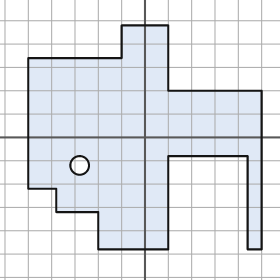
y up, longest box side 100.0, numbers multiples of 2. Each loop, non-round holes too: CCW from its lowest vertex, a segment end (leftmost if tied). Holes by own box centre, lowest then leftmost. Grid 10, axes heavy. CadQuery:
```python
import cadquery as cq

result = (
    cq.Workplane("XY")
    .moveTo(-20.0, -48.0)
    .lineTo(10.0, -48.0)
    .lineTo(10.0, -8.0)
    .lineTo(44.0, -8.0)
    .lineTo(44.0, -48.0)
    .lineTo(50.0, -48.0)
    .lineTo(50.0, 20.0)
    .lineTo(10.0, 20.0)
    .lineTo(10.0, 48.0)
    .lineTo(-10.0, 48.0)
    .lineTo(-10.0, 34.0)
    .lineTo(-50.0, 34.0)
    .lineTo(-50.0, -22.0)
    .lineTo(-38.0, -22.0)
    .lineTo(-38.0, -32.0)
    .lineTo(-20.0, -32.0)
    .close()
    .moveTo(-28.0, -12.0)
    .circle(4.0)
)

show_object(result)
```